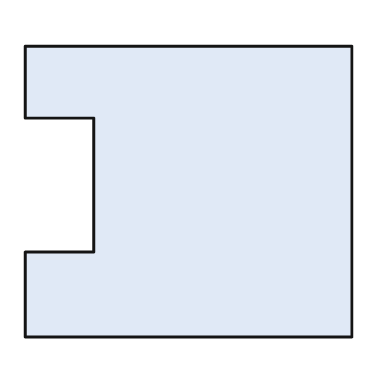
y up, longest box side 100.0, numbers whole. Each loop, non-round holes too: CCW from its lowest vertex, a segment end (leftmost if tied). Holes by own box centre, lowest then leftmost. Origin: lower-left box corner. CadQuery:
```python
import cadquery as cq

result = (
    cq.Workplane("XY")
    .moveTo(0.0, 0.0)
    .lineTo(100.0, 0.0)
    .lineTo(100.0, 89.0)
    .lineTo(0.0, 89.0)
    .lineTo(0.0, 67.0)
    .lineTo(21.0, 67.0)
    .lineTo(21.0, 26.0)
    .lineTo(0.0, 26.0)
    .close()
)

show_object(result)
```